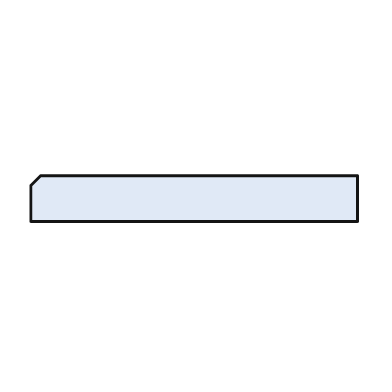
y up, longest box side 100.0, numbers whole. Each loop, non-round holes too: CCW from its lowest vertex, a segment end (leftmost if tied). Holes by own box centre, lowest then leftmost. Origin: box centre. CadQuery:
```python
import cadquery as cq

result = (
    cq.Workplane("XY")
    .moveTo(-50.0, -7.0)
    .lineTo(50.0, -7.0)
    .lineTo(50.0, 7.0)
    .lineTo(-47.0, 7.0)
    .lineTo(-50.0, 4.0)
    .close()
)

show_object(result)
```